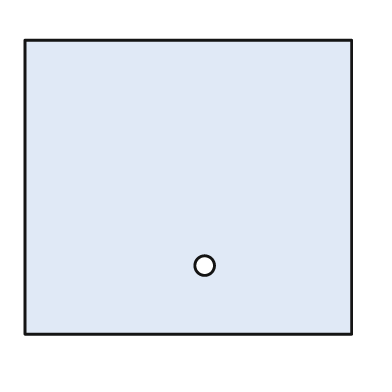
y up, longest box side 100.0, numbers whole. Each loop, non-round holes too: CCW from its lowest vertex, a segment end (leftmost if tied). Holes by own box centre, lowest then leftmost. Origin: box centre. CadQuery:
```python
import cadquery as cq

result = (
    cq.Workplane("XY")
    .moveTo(-50.0, -45.0)
    .lineTo(50.0, -45.0)
    .lineTo(50.0, 45.0)
    .lineTo(-50.0, 45.0)
    .close()
    .moveTo(5.0, -24.0)
    .circle(3.0)
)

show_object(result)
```